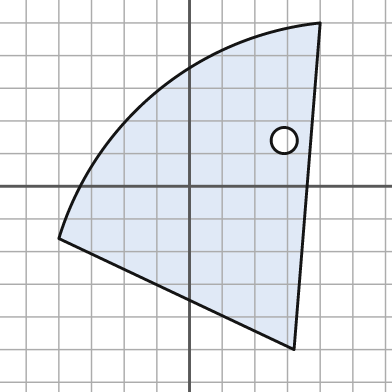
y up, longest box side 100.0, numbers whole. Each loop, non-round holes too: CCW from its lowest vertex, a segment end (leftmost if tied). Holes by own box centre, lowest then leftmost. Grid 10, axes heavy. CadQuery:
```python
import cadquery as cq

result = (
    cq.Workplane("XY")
    .moveTo(32.0, -50.0)
    .lineTo(40.0, 50.0)
    .threePointArc((-10.0, 29.0), (-40.0, -16.0))
    .close()
    .moveTo(29.0, 14.0)
    .circle(4.0)
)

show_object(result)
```